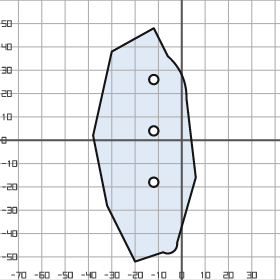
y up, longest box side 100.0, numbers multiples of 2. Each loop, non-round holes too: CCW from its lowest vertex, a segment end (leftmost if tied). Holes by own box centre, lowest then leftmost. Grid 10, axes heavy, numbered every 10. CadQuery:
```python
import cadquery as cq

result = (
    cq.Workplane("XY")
    .moveTo(-20.0, -52.0)
    .lineTo(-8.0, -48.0)
    .threePointArc((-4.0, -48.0), (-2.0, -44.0))
    .lineTo(6.0, -16.0)
    .lineTo(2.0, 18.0)
    .threePointArc((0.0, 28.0), (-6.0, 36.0))
    .lineTo(-12.0, 48.0)
    .lineTo(-30.0, 38.0)
    .lineTo(-38.0, 2.0)
    .lineTo(-32.0, -28.0)
    .close()
    .moveTo(-12.0, -18.0)
    .circle(2.0)
    .moveTo(-12.0, 4.0)
    .circle(2.0)
    .moveTo(-12.0, 26.0)
    .circle(2.0)
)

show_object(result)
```